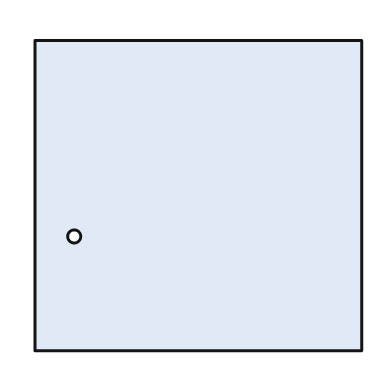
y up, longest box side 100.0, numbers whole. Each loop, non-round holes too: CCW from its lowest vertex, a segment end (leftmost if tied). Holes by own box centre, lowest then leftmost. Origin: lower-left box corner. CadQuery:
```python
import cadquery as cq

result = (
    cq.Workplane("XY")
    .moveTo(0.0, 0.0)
    .lineTo(100.0, 0.0)
    .lineTo(100.0, 95.0)
    .lineTo(0.0, 95.0)
    .close()
    .moveTo(12.0, 35.0)
    .circle(2.0)
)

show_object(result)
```